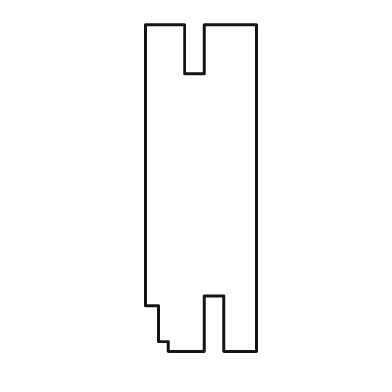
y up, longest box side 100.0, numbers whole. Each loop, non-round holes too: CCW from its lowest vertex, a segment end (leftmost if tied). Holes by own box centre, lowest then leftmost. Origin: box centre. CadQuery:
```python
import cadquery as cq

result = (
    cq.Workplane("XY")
    .moveTo(-10.0, -50.0)
    .lineTo(1.0, -50.0)
    .lineTo(1.0, -33.0)
    .lineTo(7.0, -33.0)
    .lineTo(7.0, -50.0)
    .lineTo(17.0, -50.0)
    .lineTo(17.0, 50.0)
    .lineTo(1.0, 50.0)
    .lineTo(1.0, 35.0)
    .lineTo(-5.0, 35.0)
    .lineTo(-5.0, 50.0)
    .lineTo(-17.0, 50.0)
    .lineTo(-17.0, -36.0)
    .lineTo(-13.0, -36.0)
    .lineTo(-13.0, -47.0)
    .lineTo(-10.0, -47.0)
    .close()
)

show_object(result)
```